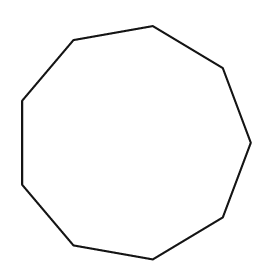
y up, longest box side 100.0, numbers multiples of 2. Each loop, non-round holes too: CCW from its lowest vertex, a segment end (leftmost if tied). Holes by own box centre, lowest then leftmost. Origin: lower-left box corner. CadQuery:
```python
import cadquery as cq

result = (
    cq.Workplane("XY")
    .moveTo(56.0, 0.0)
    .lineTo(86.0, 18.0)
    .lineTo(98.0, 50.0)
    .lineTo(86.0, 82.0)
    .lineTo(56.0, 100.0)
    .lineTo(22.0, 94.0)
    .lineTo(0.0, 68.0)
    .lineTo(0.0, 32.0)
    .lineTo(22.0, 6.0)
    .close()
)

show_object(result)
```